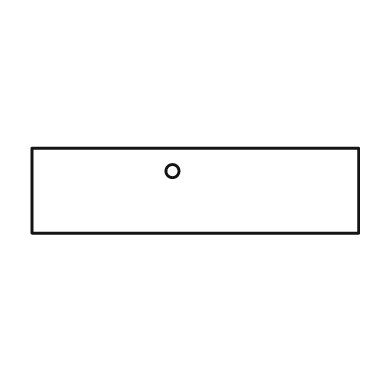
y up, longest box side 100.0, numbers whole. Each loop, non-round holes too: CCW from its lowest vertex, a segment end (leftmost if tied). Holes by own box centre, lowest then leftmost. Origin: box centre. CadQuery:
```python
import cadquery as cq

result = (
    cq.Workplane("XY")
    .moveTo(-50.0, -13.0)
    .lineTo(50.0, -13.0)
    .lineTo(50.0, 13.0)
    .lineTo(-50.0, 13.0)
    .close()
    .moveTo(-7.0, 6.0)
    .circle(2.0)
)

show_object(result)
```